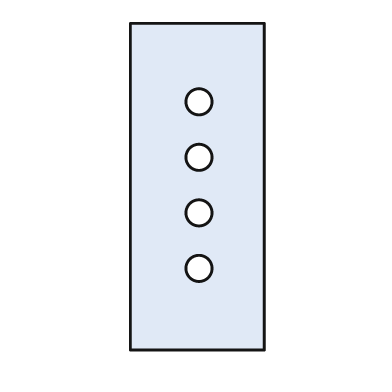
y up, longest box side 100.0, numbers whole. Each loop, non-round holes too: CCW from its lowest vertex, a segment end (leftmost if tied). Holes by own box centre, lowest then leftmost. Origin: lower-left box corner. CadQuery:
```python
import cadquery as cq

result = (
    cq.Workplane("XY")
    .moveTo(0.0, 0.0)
    .lineTo(41.0, 0.0)
    .lineTo(41.0, 100.0)
    .lineTo(0.0, 100.0)
    .close()
    .moveTo(21.0, 25.0)
    .circle(4.0)
    .moveTo(21.0, 42.0)
    .circle(4.0)
    .moveTo(21.0, 59.0)
    .circle(4.0)
    .moveTo(21.0, 76.0)
    .circle(4.0)
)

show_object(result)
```